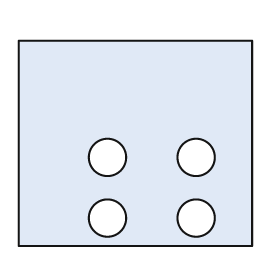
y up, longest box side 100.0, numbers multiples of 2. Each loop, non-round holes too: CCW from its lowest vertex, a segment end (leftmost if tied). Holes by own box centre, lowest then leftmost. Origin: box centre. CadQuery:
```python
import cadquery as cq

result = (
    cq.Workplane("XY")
    .moveTo(-50.0, -44.0)
    .lineTo(50.0, -44.0)
    .lineTo(50.0, 44.0)
    .lineTo(-50.0, 44.0)
    .close()
    .moveTo(-12.0, -32.0)
    .circle(8.0)
    .moveTo(26.0, -32.0)
    .circle(8.0)
    .moveTo(-12.0, -6.0)
    .circle(8.0)
    .moveTo(26.0, -6.0)
    .circle(8.0)
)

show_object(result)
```